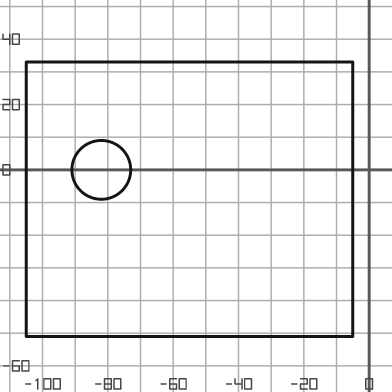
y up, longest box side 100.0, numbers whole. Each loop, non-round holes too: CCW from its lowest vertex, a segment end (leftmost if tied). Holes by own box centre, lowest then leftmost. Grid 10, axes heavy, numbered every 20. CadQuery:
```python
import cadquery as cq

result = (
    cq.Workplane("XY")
    .moveTo(-105.0, -51.0)
    .lineTo(-5.0, -51.0)
    .lineTo(-5.0, 33.0)
    .lineTo(-105.0, 33.0)
    .close()
    .moveTo(-82.0, 0.0)
    .circle(9.0)
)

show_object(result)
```